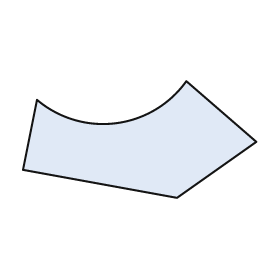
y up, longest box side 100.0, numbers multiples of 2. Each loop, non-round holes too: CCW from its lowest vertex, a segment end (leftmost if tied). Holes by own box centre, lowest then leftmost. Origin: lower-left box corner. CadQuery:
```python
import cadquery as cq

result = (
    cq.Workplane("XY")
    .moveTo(66.0, 0.0)
    .lineTo(100.0, 24.0)
    .lineTo(70.0, 50.0)
    .threePointArc((40.0, 32.0), (6.0, 42.0))
    .lineTo(0.0, 12.0)
    .close()
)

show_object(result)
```